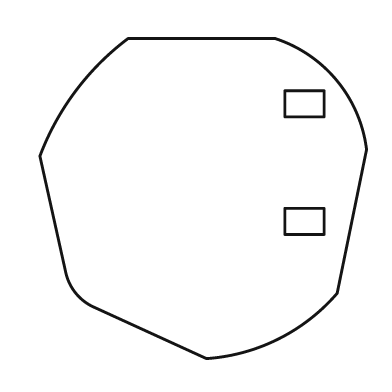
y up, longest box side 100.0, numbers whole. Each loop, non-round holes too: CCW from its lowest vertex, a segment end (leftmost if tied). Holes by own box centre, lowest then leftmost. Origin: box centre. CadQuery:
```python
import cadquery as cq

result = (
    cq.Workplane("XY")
    .moveTo(1.0, -49.0)
    .threePointArc((23.0, -43.0), (41.0, -29.0))
    .lineTo(50.0, 15.0)
    .threePointArc((41.0, 36.0), (22.0, 49.0))
    .lineTo(-23.0, 49.0)
    .threePointArc((-39.0, 33.0), (-50.0, 13.0))
    .lineTo(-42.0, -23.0)
    .threePointArc((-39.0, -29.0), (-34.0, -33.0))
    .close()
    .moveTo(25.0, -11.0)
    .lineTo(37.0, -11.0)
    .lineTo(37.0, -3.0)
    .lineTo(25.0, -3.0)
    .close()
    .moveTo(25.0, 25.0)
    .lineTo(37.0, 25.0)
    .lineTo(37.0, 33.0)
    .lineTo(25.0, 33.0)
    .close()
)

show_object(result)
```